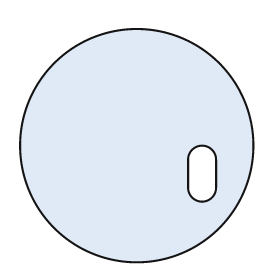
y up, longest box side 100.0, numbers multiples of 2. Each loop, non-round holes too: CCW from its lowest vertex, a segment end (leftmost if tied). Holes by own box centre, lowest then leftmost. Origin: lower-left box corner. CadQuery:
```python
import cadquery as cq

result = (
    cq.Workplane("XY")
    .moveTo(50.0, 50.0)
    .circle(50.0)
    .moveTo(72.0, 32.0)
    .threePointArc((78.0, 26.0), (84.0, 32.0))
    .lineTo(84.0, 44.0)
    .threePointArc((78.0, 50.0), (72.0, 44.0))
    .close()
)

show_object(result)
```